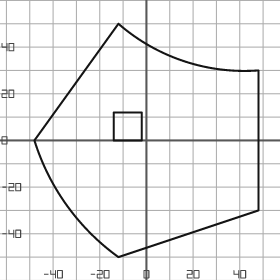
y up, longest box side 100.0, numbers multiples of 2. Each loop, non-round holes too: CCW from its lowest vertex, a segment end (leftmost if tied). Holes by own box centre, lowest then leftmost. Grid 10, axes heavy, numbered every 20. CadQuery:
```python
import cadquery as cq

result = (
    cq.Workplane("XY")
    .moveTo(-12.0, -50.0)
    .lineTo(48.0, -30.0)
    .lineTo(48.0, 30.0)
    .threePointArc((16.0, 34.0), (-12.0, 50.0))
    .lineTo(-48.0, 0.0)
    .threePointArc((-34.0, -28.0), (-12.0, -50.0))
    .close()
    .moveTo(-14.0, 0.0)
    .lineTo(-2.0, 0.0)
    .lineTo(-2.0, 12.0)
    .lineTo(-14.0, 12.0)
    .close()
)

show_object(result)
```